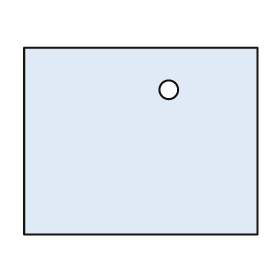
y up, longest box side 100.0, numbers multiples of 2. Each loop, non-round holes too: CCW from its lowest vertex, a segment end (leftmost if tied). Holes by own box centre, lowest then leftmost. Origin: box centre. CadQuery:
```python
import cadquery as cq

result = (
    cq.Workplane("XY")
    .moveTo(-50.0, -40.0)
    .lineTo(50.0, -40.0)
    .lineTo(50.0, 40.0)
    .lineTo(-50.0, 40.0)
    .close()
    .moveTo(12.0, 22.0)
    .circle(4.0)
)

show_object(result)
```